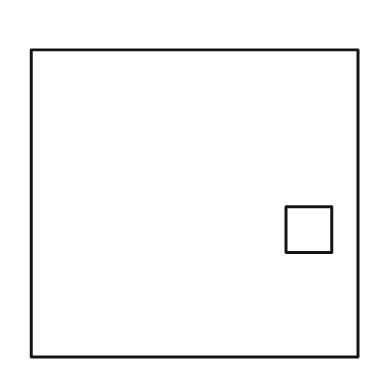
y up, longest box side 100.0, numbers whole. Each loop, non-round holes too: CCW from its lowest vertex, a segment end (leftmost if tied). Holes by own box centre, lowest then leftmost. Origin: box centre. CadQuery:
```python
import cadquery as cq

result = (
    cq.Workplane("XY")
    .moveTo(-50.0, -47.0)
    .lineTo(50.0, -47.0)
    .lineTo(50.0, 47.0)
    .lineTo(-50.0, 47.0)
    .close()
    .moveTo(28.0, -15.0)
    .lineTo(42.0, -15.0)
    .lineTo(42.0, -1.0)
    .lineTo(28.0, -1.0)
    .close()
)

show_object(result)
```